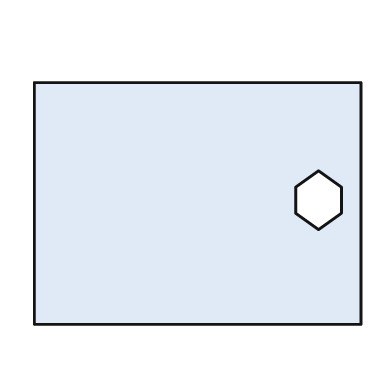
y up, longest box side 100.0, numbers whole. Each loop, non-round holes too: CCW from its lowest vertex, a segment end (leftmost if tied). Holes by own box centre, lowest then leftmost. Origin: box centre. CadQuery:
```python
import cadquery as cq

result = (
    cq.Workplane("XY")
    .moveTo(-50.0, -37.0)
    .lineTo(50.0, -37.0)
    .lineTo(50.0, 37.0)
    .lineTo(-50.0, 37.0)
    .close()
    .moveTo(37.0, -8.0)
    .lineTo(44.0, -3.0)
    .lineTo(44.0, 5.0)
    .lineTo(37.0, 10.0)
    .lineTo(30.0, 5.0)
    .lineTo(30.0, -3.0)
    .close()
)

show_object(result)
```